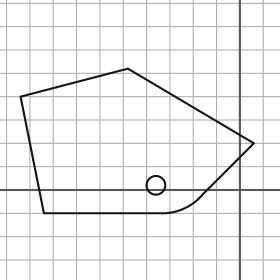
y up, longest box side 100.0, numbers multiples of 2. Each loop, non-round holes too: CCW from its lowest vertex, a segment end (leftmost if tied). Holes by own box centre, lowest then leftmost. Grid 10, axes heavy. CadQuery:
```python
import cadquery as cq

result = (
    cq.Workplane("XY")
    .moveTo(-84.0, -10.0)
    .lineTo(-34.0, -10.0)
    .threePointArc((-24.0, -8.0), (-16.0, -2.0))
    .lineTo(6.0, 20.0)
    .lineTo(-48.0, 52.0)
    .lineTo(-94.0, 40.0)
    .close()
    .moveTo(-36.0, 2.0)
    .circle(4.0)
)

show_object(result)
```